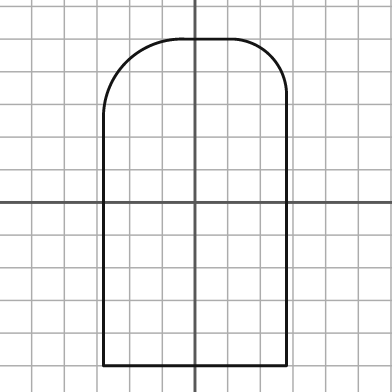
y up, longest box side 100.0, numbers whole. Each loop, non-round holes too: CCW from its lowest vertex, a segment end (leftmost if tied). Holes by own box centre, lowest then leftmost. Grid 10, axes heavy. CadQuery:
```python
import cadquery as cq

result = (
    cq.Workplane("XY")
    .moveTo(-28.0, -50.0)
    .lineTo(28.0, -50.0)
    .lineTo(28.0, 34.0)
    .threePointArc((23.0, 45.0), (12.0, 50.0))
    .lineTo(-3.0, 50.0)
    .threePointArc((-21.0, 43.0), (-28.0, 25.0))
    .close()
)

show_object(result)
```